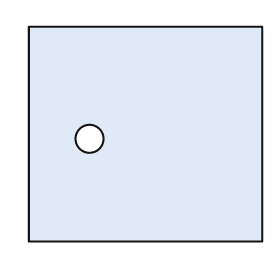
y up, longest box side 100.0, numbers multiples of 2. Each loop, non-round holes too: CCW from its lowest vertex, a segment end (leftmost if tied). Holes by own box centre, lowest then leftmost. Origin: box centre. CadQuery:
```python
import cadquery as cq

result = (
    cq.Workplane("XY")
    .moveTo(-50.0, -46.0)
    .lineTo(50.0, -46.0)
    .lineTo(50.0, 46.0)
    .lineTo(-50.0, 46.0)
    .close()
    .moveTo(-24.0, -2.0)
    .circle(6.0)
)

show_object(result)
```